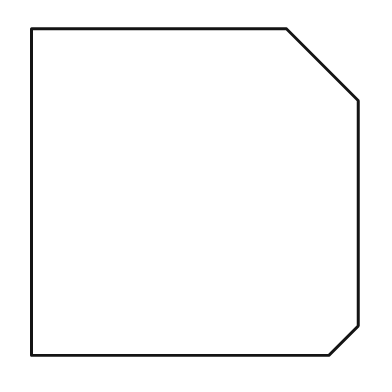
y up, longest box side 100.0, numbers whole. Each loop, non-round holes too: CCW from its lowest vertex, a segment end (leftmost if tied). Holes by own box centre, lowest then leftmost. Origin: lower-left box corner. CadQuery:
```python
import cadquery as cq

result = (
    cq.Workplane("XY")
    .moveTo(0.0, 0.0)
    .lineTo(91.0, 0.0)
    .lineTo(100.0, 9.0)
    .lineTo(100.0, 78.0)
    .lineTo(78.0, 100.0)
    .lineTo(0.0, 100.0)
    .close()
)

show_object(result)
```